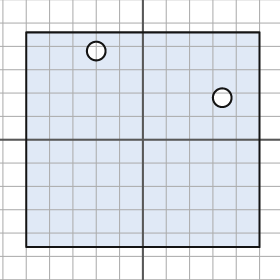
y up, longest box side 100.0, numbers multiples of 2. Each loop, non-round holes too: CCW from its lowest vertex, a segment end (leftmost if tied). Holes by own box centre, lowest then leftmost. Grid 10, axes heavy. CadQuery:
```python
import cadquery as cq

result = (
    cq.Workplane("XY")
    .moveTo(-50.0, -46.0)
    .lineTo(50.0, -46.0)
    .lineTo(50.0, 46.0)
    .lineTo(-50.0, 46.0)
    .close()
    .moveTo(34.0, 18.0)
    .circle(4.0)
    .moveTo(-20.0, 38.0)
    .circle(4.0)
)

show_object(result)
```